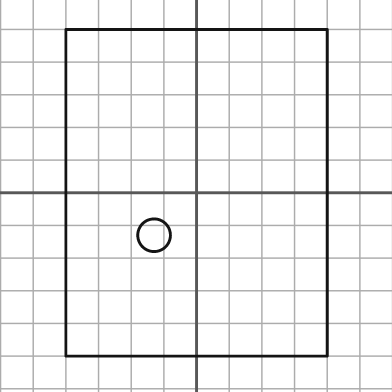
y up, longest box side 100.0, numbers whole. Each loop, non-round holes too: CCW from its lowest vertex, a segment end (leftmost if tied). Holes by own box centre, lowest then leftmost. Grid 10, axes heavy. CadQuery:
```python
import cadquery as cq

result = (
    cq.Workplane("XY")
    .moveTo(-40.0, -50.0)
    .lineTo(40.0, -50.0)
    .lineTo(40.0, 50.0)
    .lineTo(-40.0, 50.0)
    .close()
    .moveTo(-13.0, -13.0)
    .circle(5.0)
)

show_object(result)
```